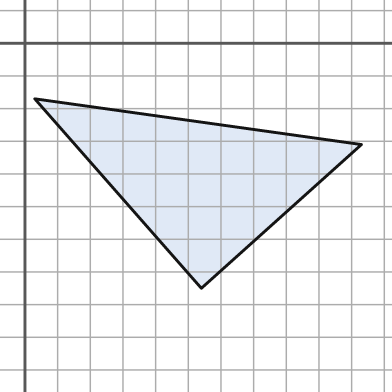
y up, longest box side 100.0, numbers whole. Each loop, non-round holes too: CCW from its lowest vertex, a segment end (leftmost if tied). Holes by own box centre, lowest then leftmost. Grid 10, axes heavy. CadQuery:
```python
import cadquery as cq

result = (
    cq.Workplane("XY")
    .moveTo(54.0, -75.0)
    .lineTo(103.0, -31.0)
    .lineTo(3.0, -17.0)
    .close()
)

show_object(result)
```